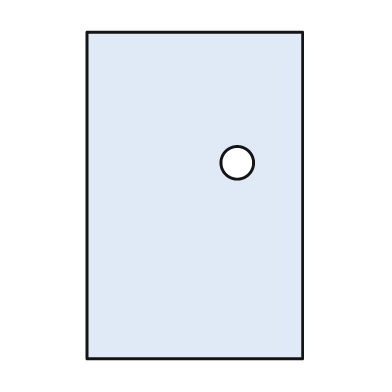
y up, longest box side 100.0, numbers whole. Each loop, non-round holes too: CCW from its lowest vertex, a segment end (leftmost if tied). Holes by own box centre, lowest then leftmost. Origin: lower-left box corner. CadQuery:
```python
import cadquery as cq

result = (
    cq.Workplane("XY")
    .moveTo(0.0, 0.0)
    .lineTo(66.0, 0.0)
    .lineTo(66.0, 100.0)
    .lineTo(0.0, 100.0)
    .close()
    .moveTo(46.0, 60.0)
    .circle(5.0)
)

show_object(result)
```